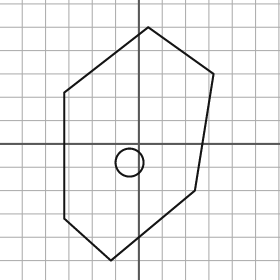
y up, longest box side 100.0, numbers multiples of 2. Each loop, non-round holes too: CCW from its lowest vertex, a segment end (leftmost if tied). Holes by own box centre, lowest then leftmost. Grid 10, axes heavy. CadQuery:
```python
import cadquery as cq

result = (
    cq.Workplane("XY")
    .moveTo(-12.0, -50.0)
    .lineTo(24.0, -20.0)
    .lineTo(32.0, 30.0)
    .lineTo(4.0, 50.0)
    .lineTo(-32.0, 22.0)
    .lineTo(-32.0, -32.0)
    .close()
    .moveTo(-4.0, -8.0)
    .circle(6.0)
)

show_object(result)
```